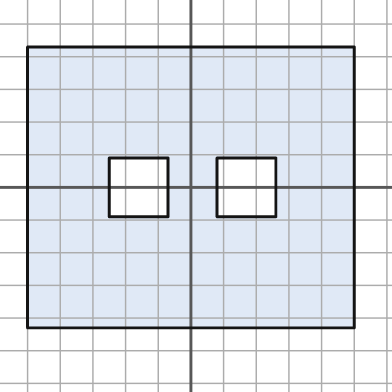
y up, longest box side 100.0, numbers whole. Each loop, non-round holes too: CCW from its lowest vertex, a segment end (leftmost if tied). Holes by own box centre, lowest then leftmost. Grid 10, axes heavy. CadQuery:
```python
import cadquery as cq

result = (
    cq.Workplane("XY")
    .moveTo(-50.0, -43.0)
    .lineTo(50.0, -43.0)
    .lineTo(50.0, 43.0)
    .lineTo(-50.0, 43.0)
    .close()
    .moveTo(-25.0, -9.0)
    .lineTo(-7.0, -9.0)
    .lineTo(-7.0, 9.0)
    .lineTo(-25.0, 9.0)
    .close()
    .moveTo(8.0, -9.0)
    .lineTo(26.0, -9.0)
    .lineTo(26.0, 9.0)
    .lineTo(8.0, 9.0)
    .close()
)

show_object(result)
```